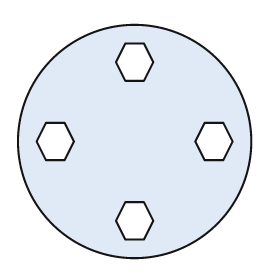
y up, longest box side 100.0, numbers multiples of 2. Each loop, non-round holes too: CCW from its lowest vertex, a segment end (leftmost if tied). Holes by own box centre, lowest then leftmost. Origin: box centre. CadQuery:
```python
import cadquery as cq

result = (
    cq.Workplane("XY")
    .moveTo(0.0, 0.0)
    .circle(50.0)
    .moveTo(-4.0, -42.0)
    .lineTo(4.0, -42.0)
    .lineTo(8.0, -34.0)
    .lineTo(4.0, -26.0)
    .lineTo(-4.0, -26.0)
    .lineTo(-8.0, -34.0)
    .close()
    .moveTo(-38.0, -8.0)
    .lineTo(-30.0, -8.0)
    .lineTo(-26.0, 0.0)
    .lineTo(-30.0, 8.0)
    .lineTo(-38.0, 8.0)
    .lineTo(-42.0, 0.0)
    .close()
    .moveTo(30.0, -8.0)
    .lineTo(38.0, -8.0)
    .lineTo(42.0, 0.0)
    .lineTo(38.0, 8.0)
    .lineTo(30.0, 8.0)
    .lineTo(26.0, 0.0)
    .close()
    .moveTo(-4.0, 26.0)
    .lineTo(4.0, 26.0)
    .lineTo(8.0, 34.0)
    .lineTo(4.0, 42.0)
    .lineTo(-4.0, 42.0)
    .lineTo(-8.0, 34.0)
    .close()
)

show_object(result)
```